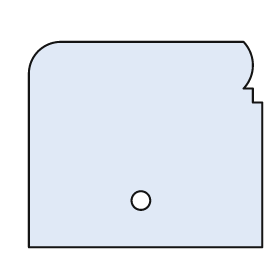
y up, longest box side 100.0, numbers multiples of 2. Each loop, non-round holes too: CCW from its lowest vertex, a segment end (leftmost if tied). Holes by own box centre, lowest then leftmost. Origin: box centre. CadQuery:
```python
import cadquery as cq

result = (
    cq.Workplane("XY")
    .moveTo(-50.0, -44.0)
    .lineTo(50.0, -44.0)
    .lineTo(50.0, 18.0)
    .lineTo(46.0, 18.0)
    .lineTo(46.0, 24.0)
    .lineTo(42.0, 24.0)
    .threePointArc((46.0, 34.0), (42.0, 44.0))
    .lineTo(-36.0, 44.0)
    .threePointArc((-46.0, 40.0), (-50.0, 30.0))
    .close()
    .moveTo(-2.0, -24.0)
    .circle(4.0)
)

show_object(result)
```